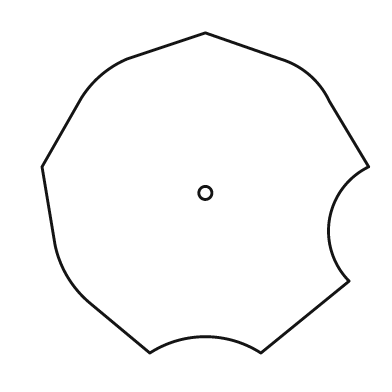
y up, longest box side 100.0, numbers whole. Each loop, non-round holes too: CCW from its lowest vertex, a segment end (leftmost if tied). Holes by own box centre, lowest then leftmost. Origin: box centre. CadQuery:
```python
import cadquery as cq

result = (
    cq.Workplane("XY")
    .moveTo(-17.0, -49.0)
    .threePointArc((0.0, -44.0), (17.0, -49.0))
    .lineTo(44.0, -27.0)
    .threePointArc((38.0, -8.0), (50.0, 8.0))
    .lineTo(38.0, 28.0)
    .threePointArc((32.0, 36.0), (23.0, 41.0))
    .lineTo(0.0, 49.0)
    .lineTo(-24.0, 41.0)
    .threePointArc((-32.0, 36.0), (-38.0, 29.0))
    .lineTo(-50.0, 8.0)
    .lineTo(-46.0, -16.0)
    .threePointArc((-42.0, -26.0), (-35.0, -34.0))
    .close()
    .moveTo(0.0, 0.0)
    .circle(2.0)
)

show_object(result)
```